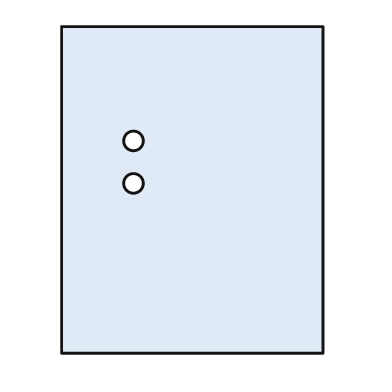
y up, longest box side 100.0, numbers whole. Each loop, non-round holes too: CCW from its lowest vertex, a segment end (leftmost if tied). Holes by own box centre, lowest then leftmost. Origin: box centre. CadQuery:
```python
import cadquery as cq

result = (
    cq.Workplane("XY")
    .moveTo(-40.0, -50.0)
    .lineTo(40.0, -50.0)
    .lineTo(40.0, 50.0)
    .lineTo(-40.0, 50.0)
    .close()
    .moveTo(-18.0, 2.0)
    .circle(3.0)
    .moveTo(-18.0, 15.0)
    .circle(3.0)
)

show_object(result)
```